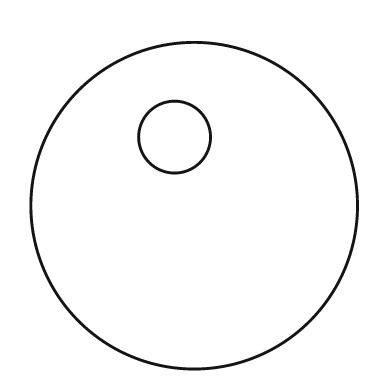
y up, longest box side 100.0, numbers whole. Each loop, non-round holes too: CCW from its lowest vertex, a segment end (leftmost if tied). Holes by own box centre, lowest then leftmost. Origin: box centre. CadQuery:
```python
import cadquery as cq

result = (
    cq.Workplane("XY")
    .moveTo(0.0, 0.0)
    .circle(50.0)
    .moveTo(-6.0, 21.0)
    .circle(11.0)
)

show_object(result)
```